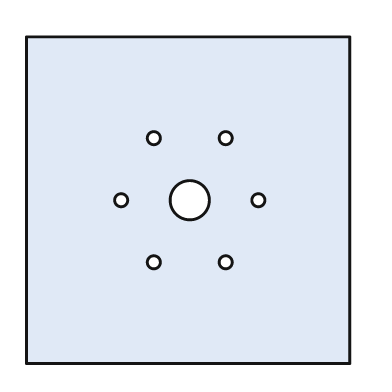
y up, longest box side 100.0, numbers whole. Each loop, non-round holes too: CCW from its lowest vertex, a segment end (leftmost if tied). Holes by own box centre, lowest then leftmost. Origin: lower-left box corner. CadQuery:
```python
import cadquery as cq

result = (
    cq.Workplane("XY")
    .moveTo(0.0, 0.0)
    .lineTo(99.0, 0.0)
    .lineTo(99.0, 100.0)
    .lineTo(0.0, 100.0)
    .close()
    .moveTo(39.0, 31.0)
    .circle(2.0)
    .moveTo(61.0, 31.0)
    .circle(2.0)
    .moveTo(29.0, 50.0)
    .circle(2.0)
    .moveTo(50.0, 50.0)
    .circle(6.0)
    .moveTo(71.0, 50.0)
    .circle(2.0)
    .moveTo(39.0, 69.0)
    .circle(2.0)
    .moveTo(61.0, 69.0)
    .circle(2.0)
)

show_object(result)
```